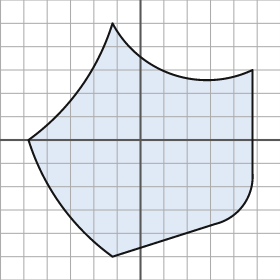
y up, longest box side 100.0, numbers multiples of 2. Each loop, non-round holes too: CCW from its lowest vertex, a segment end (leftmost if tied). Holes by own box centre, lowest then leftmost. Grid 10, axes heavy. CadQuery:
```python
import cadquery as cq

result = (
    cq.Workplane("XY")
    .moveTo(-12.0, -50.0)
    .lineTo(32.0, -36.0)
    .threePointArc((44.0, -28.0), (48.0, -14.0))
    .lineTo(48.0, 30.0)
    .threePointArc((14.0, 28.0), (-12.0, 50.0))
    .threePointArc((-26.0, 22.0), (-48.0, 0.0))
    .threePointArc((-34.0, -28.0), (-12.0, -50.0))
    .close()
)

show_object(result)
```